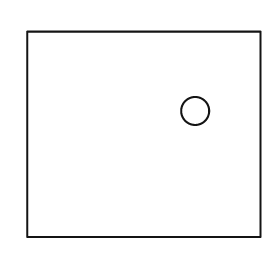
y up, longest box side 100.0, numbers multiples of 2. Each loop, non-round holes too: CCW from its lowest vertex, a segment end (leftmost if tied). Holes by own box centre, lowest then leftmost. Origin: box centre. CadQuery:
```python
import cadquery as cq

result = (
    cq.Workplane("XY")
    .moveTo(-50.0, -44.0)
    .lineTo(50.0, -44.0)
    .lineTo(50.0, 44.0)
    .lineTo(-50.0, 44.0)
    .close()
    .moveTo(22.0, 10.0)
    .circle(6.0)
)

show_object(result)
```